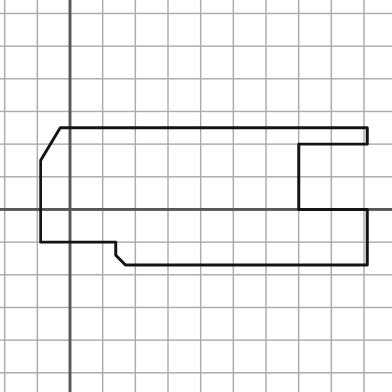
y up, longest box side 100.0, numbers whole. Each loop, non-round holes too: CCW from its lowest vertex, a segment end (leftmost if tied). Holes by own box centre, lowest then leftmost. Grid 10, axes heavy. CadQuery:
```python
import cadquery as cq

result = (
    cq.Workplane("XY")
    .moveTo(17.0, -17.0)
    .lineTo(91.0, -17.0)
    .lineTo(91.0, 0.0)
    .lineTo(70.0, 0.0)
    .lineTo(70.0, 20.0)
    .lineTo(91.0, 20.0)
    .lineTo(91.0, 25.0)
    .lineTo(-3.0, 25.0)
    .lineTo(-9.0, 15.0)
    .lineTo(-9.0, -10.0)
    .lineTo(14.0, -10.0)
    .lineTo(14.0, -14.0)
    .close()
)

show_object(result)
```